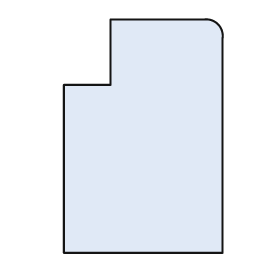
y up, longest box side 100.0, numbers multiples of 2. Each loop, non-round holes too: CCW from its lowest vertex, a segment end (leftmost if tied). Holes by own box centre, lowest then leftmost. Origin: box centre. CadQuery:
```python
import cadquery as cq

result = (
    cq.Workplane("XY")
    .moveTo(-34.0, -50.0)
    .lineTo(34.0, -50.0)
    .lineTo(34.0, 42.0)
    .threePointArc((32.0, 48.0), (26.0, 50.0))
    .lineTo(-14.0, 50.0)
    .lineTo(-14.0, 22.0)
    .lineTo(-34.0, 22.0)
    .close()
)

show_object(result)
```